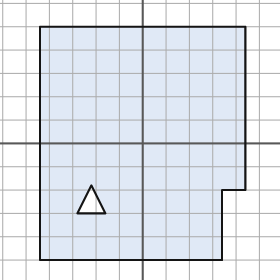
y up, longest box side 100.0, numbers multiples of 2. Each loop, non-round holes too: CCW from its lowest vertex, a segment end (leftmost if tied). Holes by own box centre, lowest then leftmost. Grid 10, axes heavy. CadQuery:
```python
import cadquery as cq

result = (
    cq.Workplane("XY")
    .moveTo(-44.0, -50.0)
    .lineTo(34.0, -50.0)
    .lineTo(34.0, -20.0)
    .lineTo(44.0, -20.0)
    .lineTo(44.0, 50.0)
    .lineTo(-44.0, 50.0)
    .close()
    .moveTo(-28.0, -30.0)
    .lineTo(-16.0, -30.0)
    .lineTo(-22.0, -18.0)
    .close()
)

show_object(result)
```